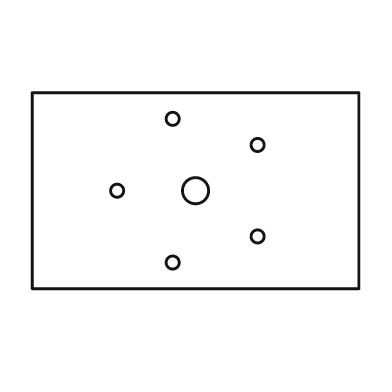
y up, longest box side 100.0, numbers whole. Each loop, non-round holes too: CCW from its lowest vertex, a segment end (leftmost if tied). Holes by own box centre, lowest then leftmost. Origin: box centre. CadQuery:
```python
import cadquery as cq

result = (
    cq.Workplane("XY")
    .moveTo(-50.0, -30.0)
    .lineTo(50.0, -30.0)
    .lineTo(50.0, 30.0)
    .lineTo(-50.0, 30.0)
    .close()
    .moveTo(-7.0, -22.0)
    .circle(2.0)
    .moveTo(19.0, -14.0)
    .circle(2.0)
    .moveTo(-24.0, 0.0)
    .circle(2.0)
    .moveTo(0.0, 0.0)
    .circle(4.0)
    .moveTo(19.0, 14.0)
    .circle(2.0)
    .moveTo(-7.0, 22.0)
    .circle(2.0)
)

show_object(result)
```